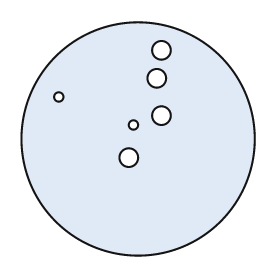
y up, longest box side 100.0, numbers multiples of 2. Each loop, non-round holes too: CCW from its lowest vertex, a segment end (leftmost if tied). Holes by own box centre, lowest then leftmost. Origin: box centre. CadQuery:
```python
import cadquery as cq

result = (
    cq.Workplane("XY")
    .moveTo(0.0, 0.0)
    .circle(50.0)
    .moveTo(-4.0, -8.0)
    .circle(4.0)
    .moveTo(-2.0, 6.0)
    .circle(2.0)
    .moveTo(10.0, 10.0)
    .circle(4.0)
    .moveTo(-34.0, 18.0)
    .circle(2.0)
    .moveTo(8.0, 26.0)
    .circle(4.0)
    .moveTo(10.0, 38.0)
    .circle(4.0)
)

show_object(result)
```